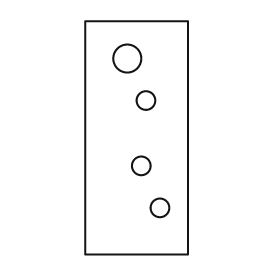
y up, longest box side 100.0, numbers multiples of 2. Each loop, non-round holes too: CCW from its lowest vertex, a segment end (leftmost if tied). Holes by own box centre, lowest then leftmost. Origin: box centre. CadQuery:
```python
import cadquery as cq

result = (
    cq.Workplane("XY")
    .moveTo(-22.0, -50.0)
    .lineTo(22.0, -50.0)
    .lineTo(22.0, 50.0)
    .lineTo(-22.0, 50.0)
    .close()
    .moveTo(10.0, -30.0)
    .circle(4.0)
    .moveTo(2.0, -12.0)
    .circle(4.0)
    .moveTo(4.0, 16.0)
    .circle(4.0)
    .moveTo(-4.0, 34.0)
    .circle(6.0)
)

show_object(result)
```